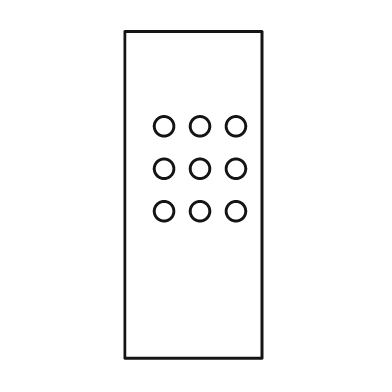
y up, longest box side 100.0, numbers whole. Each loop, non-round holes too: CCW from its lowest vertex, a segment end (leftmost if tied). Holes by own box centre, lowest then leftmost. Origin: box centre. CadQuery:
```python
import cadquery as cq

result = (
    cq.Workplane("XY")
    .moveTo(-21.0, -50.0)
    .lineTo(21.0, -50.0)
    .lineTo(21.0, 50.0)
    .lineTo(-21.0, 50.0)
    .close()
    .moveTo(-9.0, -5.0)
    .circle(3.0)
    .moveTo(2.0, -5.0)
    .circle(3.0)
    .moveTo(13.0, -5.0)
    .circle(3.0)
    .moveTo(-9.0, 8.0)
    .circle(3.0)
    .moveTo(2.0, 8.0)
    .circle(3.0)
    .moveTo(13.0, 8.0)
    .circle(3.0)
    .moveTo(-9.0, 21.0)
    .circle(3.0)
    .moveTo(2.0, 21.0)
    .circle(3.0)
    .moveTo(13.0, 21.0)
    .circle(3.0)
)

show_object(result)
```